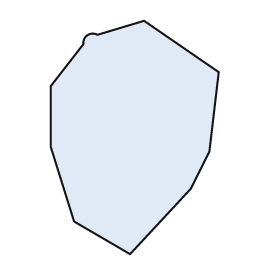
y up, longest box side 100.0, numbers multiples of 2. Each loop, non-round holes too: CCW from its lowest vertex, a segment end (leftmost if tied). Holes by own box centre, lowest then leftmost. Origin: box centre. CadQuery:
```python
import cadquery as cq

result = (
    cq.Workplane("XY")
    .moveTo(-2.0, -50.0)
    .lineTo(24.0, -22.0)
    .lineTo(32.0, -6.0)
    .lineTo(36.0, 28.0)
    .lineTo(4.0, 50.0)
    .lineTo(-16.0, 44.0)
    .threePointArc((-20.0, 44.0), (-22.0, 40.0))
    .lineTo(-36.0, 22.0)
    .lineTo(-36.0, -4.0)
    .lineTo(-26.0, -36.0)
    .close()
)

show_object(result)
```